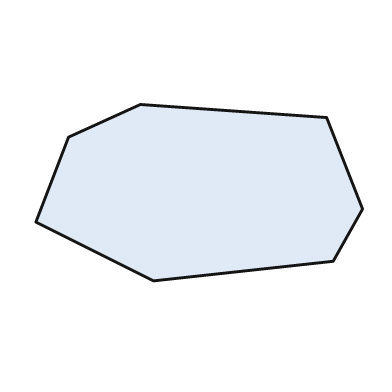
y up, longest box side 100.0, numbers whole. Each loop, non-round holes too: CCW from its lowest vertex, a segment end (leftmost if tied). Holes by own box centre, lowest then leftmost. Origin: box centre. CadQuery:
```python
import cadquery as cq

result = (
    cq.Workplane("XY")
    .moveTo(-14.0, -27.0)
    .lineTo(41.0, -21.0)
    .lineTo(50.0, -5.0)
    .lineTo(39.0, 23.0)
    .lineTo(-18.0, 27.0)
    .lineTo(-40.0, 17.0)
    .lineTo(-50.0, -9.0)
    .close()
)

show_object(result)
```